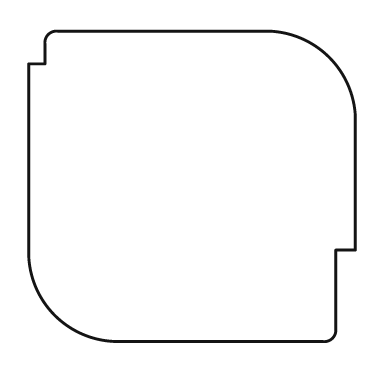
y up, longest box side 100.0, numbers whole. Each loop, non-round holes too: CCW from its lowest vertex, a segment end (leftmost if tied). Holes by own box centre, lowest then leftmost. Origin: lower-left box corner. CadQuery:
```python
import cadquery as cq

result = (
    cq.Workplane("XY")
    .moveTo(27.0, 0.0)
    .lineTo(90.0, 0.0)
    .threePointArc((93.0, 1.0), (94.0, 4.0))
    .lineTo(94.0, 28.0)
    .lineTo(100.0, 28.0)
    .lineTo(100.0, 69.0)
    .threePointArc((92.0, 87.0), (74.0, 95.0))
    .lineTo(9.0, 95.0)
    .threePointArc((6.0, 94.0), (5.0, 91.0))
    .lineTo(5.0, 85.0)
    .lineTo(0.0, 85.0)
    .lineTo(0.0, 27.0)
    .threePointArc((8.0, 8.0), (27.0, 0.0))
    .close()
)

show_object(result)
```